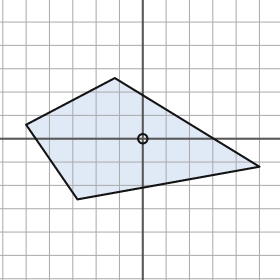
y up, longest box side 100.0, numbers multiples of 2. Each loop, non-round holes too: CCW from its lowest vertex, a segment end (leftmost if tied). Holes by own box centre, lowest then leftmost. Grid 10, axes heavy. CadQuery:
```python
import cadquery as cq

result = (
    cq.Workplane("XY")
    .moveTo(-28.0, -26.0)
    .lineTo(50.0, -12.0)
    .lineTo(-12.0, 26.0)
    .lineTo(-50.0, 6.0)
    .close()
    .moveTo(0.0, 0.0)
    .circle(2.0)
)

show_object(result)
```